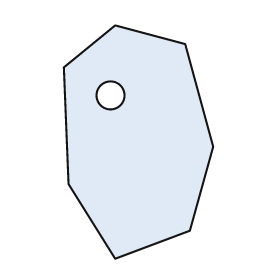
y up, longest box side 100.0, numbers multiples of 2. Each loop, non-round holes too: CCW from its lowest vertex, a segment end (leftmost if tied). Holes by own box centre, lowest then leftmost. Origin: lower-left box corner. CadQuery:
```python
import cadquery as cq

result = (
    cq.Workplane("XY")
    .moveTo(22.0, 0.0)
    .lineTo(54.0, 12.0)
    .lineTo(64.0, 48.0)
    .lineTo(52.0, 92.0)
    .lineTo(22.0, 100.0)
    .lineTo(0.0, 82.0)
    .lineTo(2.0, 32.0)
    .close()
    .moveTo(20.0, 70.0)
    .circle(6.0)
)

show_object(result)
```